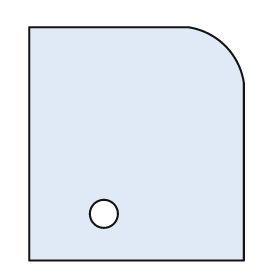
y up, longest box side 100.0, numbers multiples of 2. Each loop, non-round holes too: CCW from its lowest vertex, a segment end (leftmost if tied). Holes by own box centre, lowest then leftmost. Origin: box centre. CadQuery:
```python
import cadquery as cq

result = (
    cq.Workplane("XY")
    .moveTo(-46.0, -50.0)
    .lineTo(46.0, -50.0)
    .lineTo(46.0, 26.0)
    .threePointArc((38.0, 42.0), (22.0, 50.0))
    .lineTo(-46.0, 50.0)
    .close()
    .moveTo(-14.0, -30.0)
    .circle(6.0)
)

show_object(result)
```